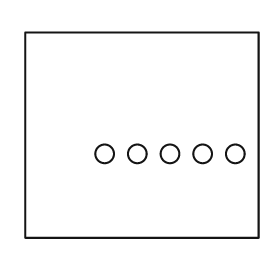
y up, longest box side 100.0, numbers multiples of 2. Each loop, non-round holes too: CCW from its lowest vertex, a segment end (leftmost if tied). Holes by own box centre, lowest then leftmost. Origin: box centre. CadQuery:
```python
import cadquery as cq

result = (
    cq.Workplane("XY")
    .moveTo(-50.0, -44.0)
    .lineTo(50.0, -44.0)
    .lineTo(50.0, 44.0)
    .lineTo(-50.0, 44.0)
    .close()
    .moveTo(-16.0, -8.0)
    .circle(4.0)
    .moveTo(-2.0, -8.0)
    .circle(4.0)
    .moveTo(12.0, -8.0)
    .circle(4.0)
    .moveTo(26.0, -8.0)
    .circle(4.0)
    .moveTo(40.0, -8.0)
    .circle(4.0)
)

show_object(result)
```